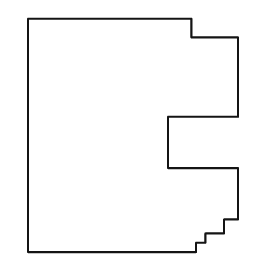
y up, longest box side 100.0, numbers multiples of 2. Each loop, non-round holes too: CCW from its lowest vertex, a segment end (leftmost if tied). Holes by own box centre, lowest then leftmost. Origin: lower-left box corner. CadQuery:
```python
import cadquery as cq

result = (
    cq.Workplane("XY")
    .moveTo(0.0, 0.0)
    .lineTo(72.0, 0.0)
    .lineTo(72.0, 4.0)
    .lineTo(76.0, 4.0)
    .lineTo(76.0, 8.0)
    .lineTo(84.0, 8.0)
    .lineTo(84.0, 14.0)
    .lineTo(90.0, 14.0)
    .lineTo(90.0, 36.0)
    .lineTo(60.0, 36.0)
    .lineTo(60.0, 58.0)
    .lineTo(90.0, 58.0)
    .lineTo(90.0, 92.0)
    .lineTo(70.0, 92.0)
    .lineTo(70.0, 100.0)
    .lineTo(0.0, 100.0)
    .close()
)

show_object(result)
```